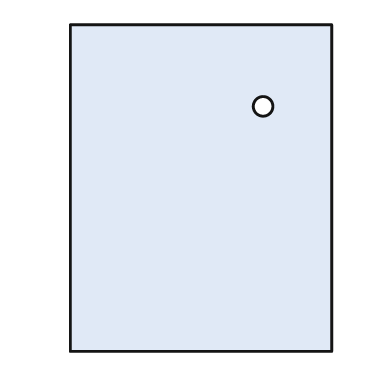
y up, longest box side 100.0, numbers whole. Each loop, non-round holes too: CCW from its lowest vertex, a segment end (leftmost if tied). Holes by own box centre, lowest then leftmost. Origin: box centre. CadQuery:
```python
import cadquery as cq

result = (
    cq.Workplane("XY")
    .moveTo(-40.0, -50.0)
    .lineTo(40.0, -50.0)
    .lineTo(40.0, 50.0)
    .lineTo(-40.0, 50.0)
    .close()
    .moveTo(19.0, 25.0)
    .circle(3.0)
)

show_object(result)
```